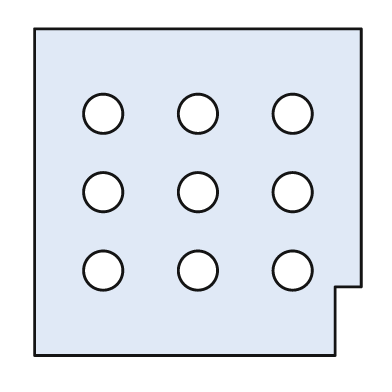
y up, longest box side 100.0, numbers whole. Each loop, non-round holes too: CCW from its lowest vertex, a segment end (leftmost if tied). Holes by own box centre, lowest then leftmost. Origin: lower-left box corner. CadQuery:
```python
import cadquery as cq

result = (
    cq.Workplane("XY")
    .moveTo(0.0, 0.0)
    .lineTo(92.0, 0.0)
    .lineTo(92.0, 21.0)
    .lineTo(100.0, 21.0)
    .lineTo(100.0, 100.0)
    .lineTo(0.0, 100.0)
    .close()
    .moveTo(21.0, 26.0)
    .circle(6.0)
    .moveTo(50.0, 26.0)
    .circle(6.0)
    .moveTo(79.0, 26.0)
    .circle(6.0)
    .moveTo(21.0, 50.0)
    .circle(6.0)
    .moveTo(50.0, 50.0)
    .circle(6.0)
    .moveTo(79.0, 50.0)
    .circle(6.0)
    .moveTo(21.0, 74.0)
    .circle(6.0)
    .moveTo(50.0, 74.0)
    .circle(6.0)
    .moveTo(79.0, 74.0)
    .circle(6.0)
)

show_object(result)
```